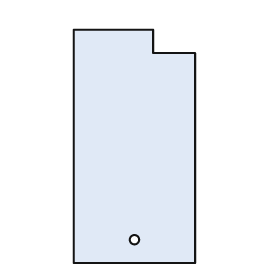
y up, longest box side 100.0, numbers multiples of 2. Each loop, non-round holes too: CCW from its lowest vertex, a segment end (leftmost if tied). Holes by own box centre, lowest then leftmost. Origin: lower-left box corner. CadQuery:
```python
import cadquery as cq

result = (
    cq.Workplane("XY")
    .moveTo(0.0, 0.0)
    .lineTo(52.0, 0.0)
    .lineTo(52.0, 90.0)
    .lineTo(34.0, 90.0)
    .lineTo(34.0, 100.0)
    .lineTo(0.0, 100.0)
    .close()
    .moveTo(26.0, 10.0)
    .circle(2.0)
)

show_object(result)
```